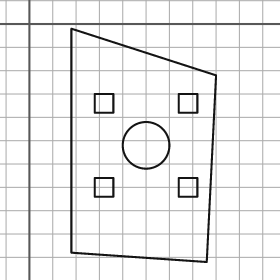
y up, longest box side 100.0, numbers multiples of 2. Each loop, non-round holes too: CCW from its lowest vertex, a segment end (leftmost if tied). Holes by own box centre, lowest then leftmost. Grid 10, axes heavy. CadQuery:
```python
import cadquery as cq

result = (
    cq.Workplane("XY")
    .moveTo(76.0, -102.0)
    .lineTo(80.0, -22.0)
    .lineTo(18.0, -2.0)
    .lineTo(18.0, -98.0)
    .close()
    .moveTo(28.0, -74.0)
    .lineTo(36.0, -74.0)
    .lineTo(36.0, -66.0)
    .lineTo(28.0, -66.0)
    .close()
    .moveTo(64.0, -74.0)
    .lineTo(72.0, -74.0)
    .lineTo(72.0, -66.0)
    .lineTo(64.0, -66.0)
    .close()
    .moveTo(50.0, -52.0)
    .circle(10.0)
    .moveTo(28.0, -38.0)
    .lineTo(36.0, -38.0)
    .lineTo(36.0, -30.0)
    .lineTo(28.0, -30.0)
    .close()
    .moveTo(64.0, -38.0)
    .lineTo(72.0, -38.0)
    .lineTo(72.0, -30.0)
    .lineTo(64.0, -30.0)
    .close()
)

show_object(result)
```